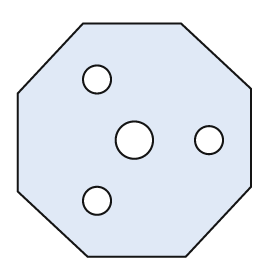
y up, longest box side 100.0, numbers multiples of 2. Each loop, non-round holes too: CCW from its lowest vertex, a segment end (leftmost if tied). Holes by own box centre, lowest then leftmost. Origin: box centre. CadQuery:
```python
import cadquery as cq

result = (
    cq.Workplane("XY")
    .moveTo(-20.0, -50.0)
    .lineTo(22.0, -50.0)
    .lineTo(50.0, -20.0)
    .lineTo(50.0, 22.0)
    .lineTo(20.0, 50.0)
    .lineTo(-22.0, 50.0)
    .lineTo(-50.0, 20.0)
    .lineTo(-50.0, -22.0)
    .close()
    .moveTo(-16.0, -26.0)
    .circle(6.0)
    .moveTo(0.0, 0.0)
    .circle(8.0)
    .moveTo(32.0, 0.0)
    .circle(6.0)
    .moveTo(-16.0, 26.0)
    .circle(6.0)
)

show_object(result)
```